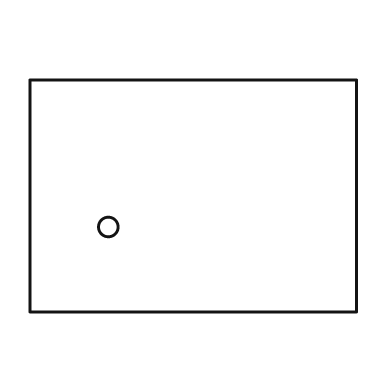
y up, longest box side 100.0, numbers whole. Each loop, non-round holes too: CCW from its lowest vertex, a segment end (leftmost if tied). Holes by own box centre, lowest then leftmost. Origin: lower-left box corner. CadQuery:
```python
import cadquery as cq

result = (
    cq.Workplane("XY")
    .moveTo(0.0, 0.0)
    .lineTo(100.0, 0.0)
    .lineTo(100.0, 71.0)
    .lineTo(0.0, 71.0)
    .close()
    .moveTo(24.0, 26.0)
    .circle(3.0)
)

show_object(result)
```